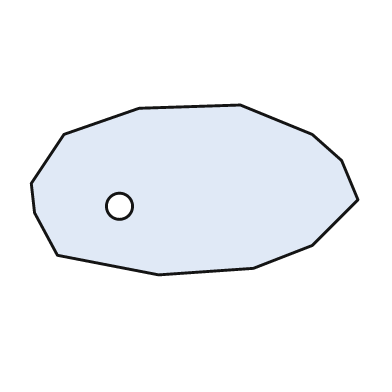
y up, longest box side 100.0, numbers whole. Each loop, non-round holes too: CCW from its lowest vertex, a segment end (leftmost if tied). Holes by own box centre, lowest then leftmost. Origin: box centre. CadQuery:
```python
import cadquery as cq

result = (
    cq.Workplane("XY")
    .moveTo(-11.0, -26.0)
    .lineTo(18.0, -24.0)
    .lineTo(36.0, -17.0)
    .lineTo(50.0, -3.0)
    .lineTo(45.0, 9.0)
    .lineTo(36.0, 17.0)
    .lineTo(14.0, 26.0)
    .lineTo(-17.0, 25.0)
    .lineTo(-40.0, 17.0)
    .lineTo(-50.0, 2.0)
    .lineTo(-49.0, -7.0)
    .lineTo(-42.0, -20.0)
    .close()
    .moveTo(-23.0, -5.0)
    .circle(4.0)
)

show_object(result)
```